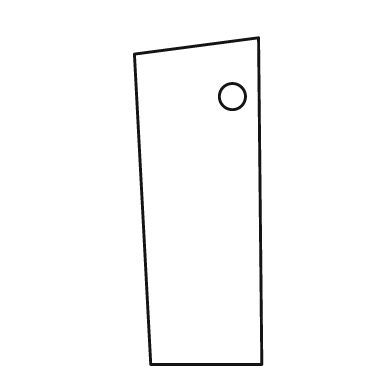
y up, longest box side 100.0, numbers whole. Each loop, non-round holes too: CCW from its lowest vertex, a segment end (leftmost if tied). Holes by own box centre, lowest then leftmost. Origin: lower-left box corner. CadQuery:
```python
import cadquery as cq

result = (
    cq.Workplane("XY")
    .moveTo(5.0, 0.0)
    .lineTo(39.0, 0.0)
    .lineTo(38.0, 100.0)
    .lineTo(0.0, 95.0)
    .close()
    .moveTo(30.0, 82.0)
    .circle(4.0)
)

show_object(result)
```